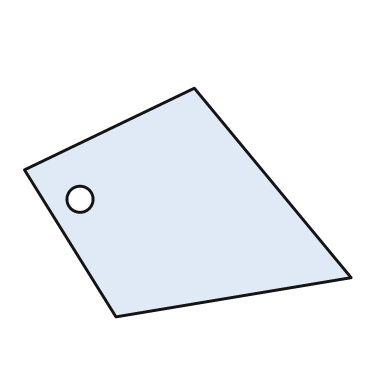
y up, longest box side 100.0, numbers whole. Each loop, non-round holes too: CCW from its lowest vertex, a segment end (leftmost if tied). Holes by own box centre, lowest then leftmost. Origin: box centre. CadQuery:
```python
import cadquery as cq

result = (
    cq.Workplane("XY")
    .moveTo(-22.0, -35.0)
    .lineTo(50.0, -23.0)
    .lineTo(2.0, 35.0)
    .lineTo(-50.0, 10.0)
    .close()
    .moveTo(-33.0, 1.0)
    .circle(4.0)
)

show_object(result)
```